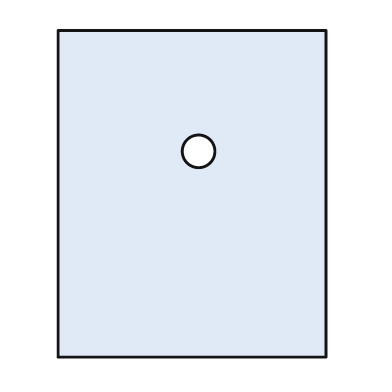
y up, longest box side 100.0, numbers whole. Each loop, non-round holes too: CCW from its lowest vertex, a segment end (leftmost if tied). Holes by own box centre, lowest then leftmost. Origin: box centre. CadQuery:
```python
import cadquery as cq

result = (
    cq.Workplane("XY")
    .moveTo(-41.0, -50.0)
    .lineTo(41.0, -50.0)
    .lineTo(41.0, 50.0)
    .lineTo(-41.0, 50.0)
    .close()
    .moveTo(2.0, 13.0)
    .circle(5.0)
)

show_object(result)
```